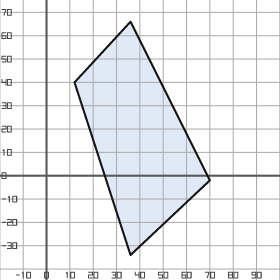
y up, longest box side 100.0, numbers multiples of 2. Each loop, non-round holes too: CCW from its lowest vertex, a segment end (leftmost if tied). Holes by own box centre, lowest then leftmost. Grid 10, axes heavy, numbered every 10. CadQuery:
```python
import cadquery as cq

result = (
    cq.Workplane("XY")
    .moveTo(36.0, -34.0)
    .lineTo(70.0, -2.0)
    .lineTo(36.0, 66.0)
    .lineTo(12.0, 40.0)
    .close()
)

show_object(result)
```